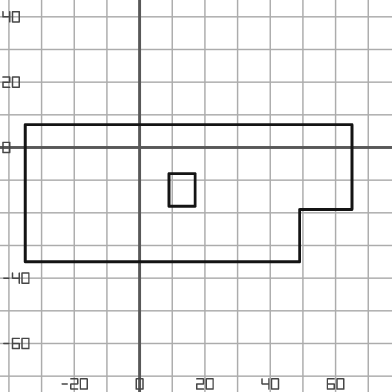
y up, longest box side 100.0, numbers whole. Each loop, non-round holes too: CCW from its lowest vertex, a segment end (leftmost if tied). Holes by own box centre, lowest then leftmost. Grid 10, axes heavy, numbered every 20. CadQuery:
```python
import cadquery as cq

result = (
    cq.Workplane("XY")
    .moveTo(-35.0, -35.0)
    .lineTo(49.0, -35.0)
    .lineTo(49.0, -19.0)
    .lineTo(65.0, -19.0)
    .lineTo(65.0, 7.0)
    .lineTo(-35.0, 7.0)
    .close()
    .moveTo(9.0, -18.0)
    .lineTo(17.0, -18.0)
    .lineTo(17.0, -8.0)
    .lineTo(9.0, -8.0)
    .close()
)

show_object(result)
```